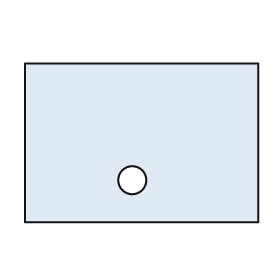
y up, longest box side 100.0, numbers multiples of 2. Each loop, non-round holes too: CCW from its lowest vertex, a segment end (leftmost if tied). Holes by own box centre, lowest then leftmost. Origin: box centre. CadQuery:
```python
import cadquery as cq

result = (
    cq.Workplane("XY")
    .moveTo(-50.0, -34.0)
    .lineTo(50.0, -34.0)
    .lineTo(50.0, 34.0)
    .lineTo(-50.0, 34.0)
    .close()
    .moveTo(-4.0, -16.0)
    .circle(6.0)
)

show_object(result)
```